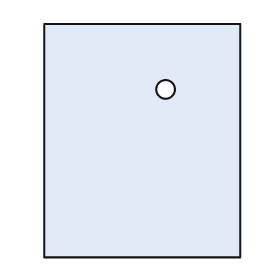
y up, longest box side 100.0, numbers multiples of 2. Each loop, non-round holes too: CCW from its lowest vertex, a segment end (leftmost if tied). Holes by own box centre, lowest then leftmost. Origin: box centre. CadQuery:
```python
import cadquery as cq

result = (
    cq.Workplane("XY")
    .moveTo(-42.0, -50.0)
    .lineTo(42.0, -50.0)
    .lineTo(42.0, 50.0)
    .lineTo(-42.0, 50.0)
    .close()
    .moveTo(10.0, 22.0)
    .circle(4.0)
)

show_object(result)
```